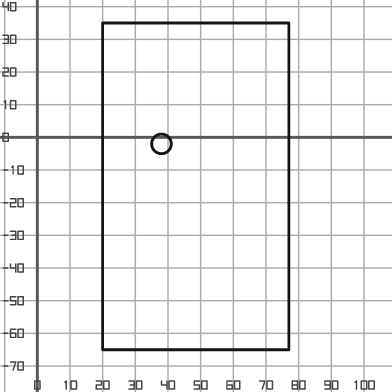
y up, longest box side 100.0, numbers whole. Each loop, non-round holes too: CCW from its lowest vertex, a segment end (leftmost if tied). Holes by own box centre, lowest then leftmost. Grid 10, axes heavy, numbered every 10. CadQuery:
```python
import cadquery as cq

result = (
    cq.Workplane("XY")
    .moveTo(20.0, -65.0)
    .lineTo(77.0, -65.0)
    .lineTo(77.0, 35.0)
    .lineTo(20.0, 35.0)
    .close()
    .moveTo(38.0, -2.0)
    .circle(3.0)
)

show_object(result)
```